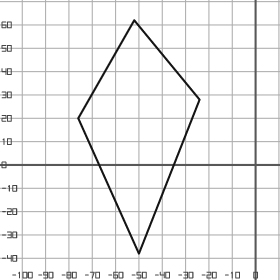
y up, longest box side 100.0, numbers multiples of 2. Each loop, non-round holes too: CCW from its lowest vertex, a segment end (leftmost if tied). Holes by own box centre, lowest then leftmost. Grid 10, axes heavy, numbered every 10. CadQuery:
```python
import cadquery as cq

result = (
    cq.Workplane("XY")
    .moveTo(-50.0, -38.0)
    .lineTo(-24.0, 28.0)
    .lineTo(-52.0, 62.0)
    .lineTo(-76.0, 20.0)
    .close()
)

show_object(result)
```